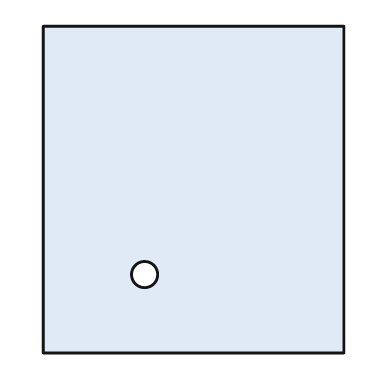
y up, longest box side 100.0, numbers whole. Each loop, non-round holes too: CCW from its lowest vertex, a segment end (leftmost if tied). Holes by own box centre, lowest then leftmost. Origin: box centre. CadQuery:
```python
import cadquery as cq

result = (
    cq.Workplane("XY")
    .moveTo(-46.0, -50.0)
    .lineTo(46.0, -50.0)
    .lineTo(46.0, 50.0)
    .lineTo(-46.0, 50.0)
    .close()
    .moveTo(-15.0, -26.0)
    .circle(4.0)
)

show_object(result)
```